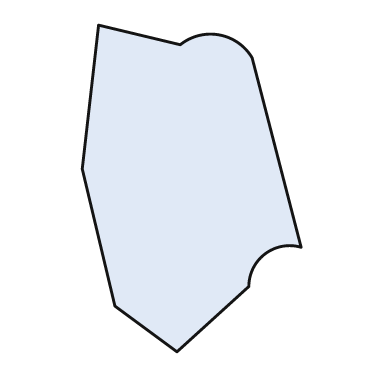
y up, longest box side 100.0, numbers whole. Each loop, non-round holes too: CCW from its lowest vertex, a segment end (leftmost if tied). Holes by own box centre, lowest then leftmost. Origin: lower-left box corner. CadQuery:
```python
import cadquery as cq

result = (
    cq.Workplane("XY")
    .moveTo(29.0, 0.0)
    .lineTo(51.0, 20.0)
    .threePointArc((56.0, 30.0), (67.0, 32.0))
    .lineTo(52.0, 90.0)
    .threePointArc((42.0, 97.0), (30.0, 94.0))
    .lineTo(5.0, 100.0)
    .lineTo(0.0, 56.0)
    .lineTo(10.0, 14.0)
    .close()
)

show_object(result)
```